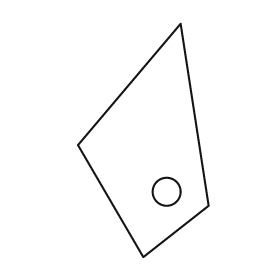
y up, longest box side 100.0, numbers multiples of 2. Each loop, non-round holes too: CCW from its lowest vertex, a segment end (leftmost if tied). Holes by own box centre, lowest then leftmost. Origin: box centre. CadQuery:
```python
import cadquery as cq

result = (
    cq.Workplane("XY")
    .moveTo(0.0, -50.0)
    .lineTo(28.0, -28.0)
    .lineTo(16.0, 50.0)
    .lineTo(-28.0, -2.0)
    .close()
    .moveTo(10.0, -22.0)
    .circle(6.0)
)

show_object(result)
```